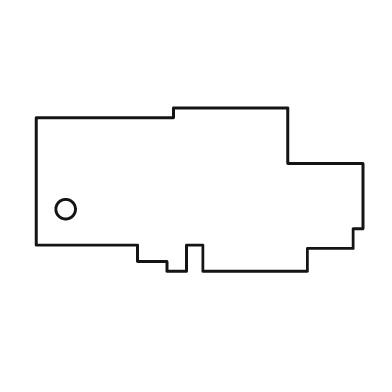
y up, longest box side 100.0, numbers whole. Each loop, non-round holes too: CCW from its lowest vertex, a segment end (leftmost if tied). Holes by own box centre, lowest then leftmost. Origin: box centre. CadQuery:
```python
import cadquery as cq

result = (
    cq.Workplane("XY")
    .moveTo(-10.0, -25.0)
    .lineTo(-4.0, -25.0)
    .lineTo(-4.0, -17.0)
    .lineTo(1.0, -17.0)
    .lineTo(1.0, -25.0)
    .lineTo(33.0, -25.0)
    .lineTo(33.0, -18.0)
    .lineTo(47.0, -18.0)
    .lineTo(47.0, -12.0)
    .lineTo(50.0, -12.0)
    .lineTo(50.0, 8.0)
    .lineTo(27.0, 8.0)
    .lineTo(27.0, 25.0)
    .lineTo(-8.0, 25.0)
    .lineTo(-8.0, 22.0)
    .lineTo(-50.0, 22.0)
    .lineTo(-50.0, -17.0)
    .lineTo(-19.0, -17.0)
    .lineTo(-19.0, -22.0)
    .lineTo(-10.0, -22.0)
    .close()
    .moveTo(-41.0, -6.0)
    .circle(3.0)
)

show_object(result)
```